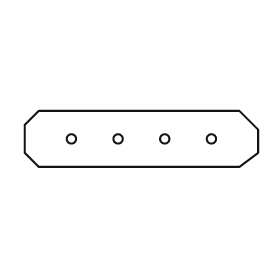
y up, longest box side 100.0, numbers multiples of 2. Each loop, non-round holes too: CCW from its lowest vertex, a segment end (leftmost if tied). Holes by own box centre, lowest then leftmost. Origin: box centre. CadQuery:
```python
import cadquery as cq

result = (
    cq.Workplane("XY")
    .moveTo(-44.0, -12.0)
    .lineTo(42.0, -12.0)
    .lineTo(50.0, -6.0)
    .lineTo(50.0, 4.0)
    .lineTo(42.0, 12.0)
    .lineTo(-44.0, 12.0)
    .lineTo(-50.0, 6.0)
    .lineTo(-50.0, -6.0)
    .close()
    .moveTo(-30.0, 0.0)
    .circle(2.0)
    .moveTo(-10.0, 0.0)
    .circle(2.0)
    .moveTo(10.0, 0.0)
    .circle(2.0)
    .moveTo(30.0, 0.0)
    .circle(2.0)
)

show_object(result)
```